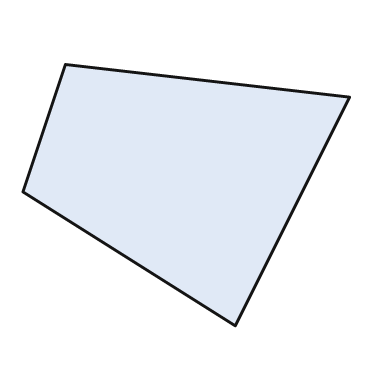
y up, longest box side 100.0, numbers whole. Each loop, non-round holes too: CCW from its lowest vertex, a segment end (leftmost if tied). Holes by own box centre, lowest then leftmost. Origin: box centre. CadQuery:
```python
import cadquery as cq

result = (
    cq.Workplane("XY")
    .moveTo(15.0, -40.0)
    .lineTo(50.0, 30.0)
    .lineTo(-37.0, 40.0)
    .lineTo(-50.0, 1.0)
    .close()
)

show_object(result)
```